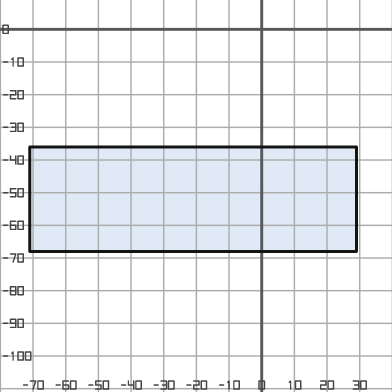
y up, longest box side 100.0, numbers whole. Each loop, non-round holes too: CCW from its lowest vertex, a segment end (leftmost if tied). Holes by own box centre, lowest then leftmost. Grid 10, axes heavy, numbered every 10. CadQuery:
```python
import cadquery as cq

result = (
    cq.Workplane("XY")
    .moveTo(-71.0, -68.0)
    .lineTo(29.0, -68.0)
    .lineTo(29.0, -36.0)
    .lineTo(-71.0, -36.0)
    .close()
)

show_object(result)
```